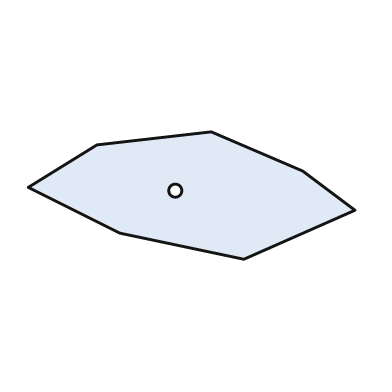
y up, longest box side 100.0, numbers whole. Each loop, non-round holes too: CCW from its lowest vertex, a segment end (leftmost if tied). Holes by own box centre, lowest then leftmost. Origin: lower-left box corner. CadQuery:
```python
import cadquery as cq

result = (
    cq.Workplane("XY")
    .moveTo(66.0, 0.0)
    .lineTo(100.0, 15.0)
    .lineTo(84.0, 27.0)
    .lineTo(56.0, 39.0)
    .lineTo(21.0, 35.0)
    .lineTo(0.0, 22.0)
    .lineTo(28.0, 8.0)
    .close()
    .moveTo(45.0, 21.0)
    .circle(2.0)
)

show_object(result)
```